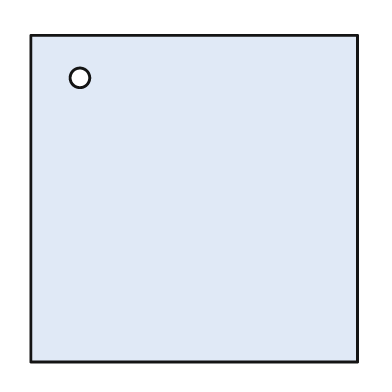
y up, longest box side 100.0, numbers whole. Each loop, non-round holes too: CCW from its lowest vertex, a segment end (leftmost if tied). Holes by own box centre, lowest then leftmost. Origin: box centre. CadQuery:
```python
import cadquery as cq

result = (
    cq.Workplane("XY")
    .moveTo(-50.0, -50.0)
    .lineTo(50.0, -50.0)
    .lineTo(50.0, 50.0)
    .lineTo(-50.0, 50.0)
    .close()
    .moveTo(-35.0, 37.0)
    .circle(3.0)
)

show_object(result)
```